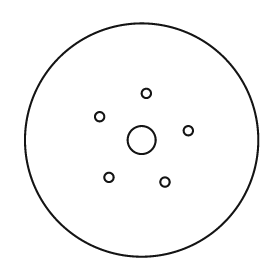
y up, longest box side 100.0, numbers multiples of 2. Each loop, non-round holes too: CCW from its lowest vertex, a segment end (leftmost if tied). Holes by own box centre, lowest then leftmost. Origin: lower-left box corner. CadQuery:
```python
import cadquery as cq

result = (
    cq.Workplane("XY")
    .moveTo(50.0, 50.0)
    .circle(50.0)
    .moveTo(60.0, 32.0)
    .circle(2.0)
    .moveTo(36.0, 34.0)
    .circle(2.0)
    .moveTo(50.0, 50.0)
    .circle(6.0)
    .moveTo(70.0, 54.0)
    .circle(2.0)
    .moveTo(32.0, 60.0)
    .circle(2.0)
    .moveTo(52.0, 70.0)
    .circle(2.0)
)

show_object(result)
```